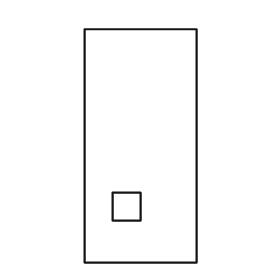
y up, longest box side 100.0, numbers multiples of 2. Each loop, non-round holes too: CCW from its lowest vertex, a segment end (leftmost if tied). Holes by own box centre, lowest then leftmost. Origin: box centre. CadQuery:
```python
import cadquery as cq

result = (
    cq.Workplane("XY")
    .moveTo(-24.0, -50.0)
    .lineTo(24.0, -50.0)
    .lineTo(24.0, 50.0)
    .lineTo(-24.0, 50.0)
    .close()
    .moveTo(-12.0, -32.0)
    .lineTo(0.0, -32.0)
    .lineTo(0.0, -20.0)
    .lineTo(-12.0, -20.0)
    .close()
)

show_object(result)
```